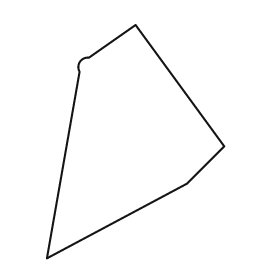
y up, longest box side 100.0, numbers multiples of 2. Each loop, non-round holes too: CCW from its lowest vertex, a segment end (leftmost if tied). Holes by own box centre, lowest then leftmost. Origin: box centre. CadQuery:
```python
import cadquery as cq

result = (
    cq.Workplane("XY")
    .moveTo(-38.0, -50.0)
    .lineTo(22.0, -18.0)
    .lineTo(38.0, -2.0)
    .lineTo(0.0, 50.0)
    .lineTo(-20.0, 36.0)
    .threePointArc((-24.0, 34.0), (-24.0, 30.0))
    .close()
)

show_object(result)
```